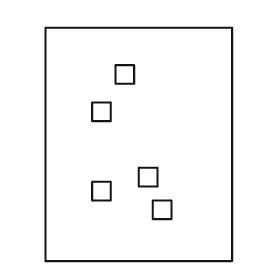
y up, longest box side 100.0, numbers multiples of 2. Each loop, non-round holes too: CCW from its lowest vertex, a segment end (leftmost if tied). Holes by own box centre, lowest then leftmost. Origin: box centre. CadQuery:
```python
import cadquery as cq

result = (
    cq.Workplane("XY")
    .moveTo(-40.0, -50.0)
    .lineTo(40.0, -50.0)
    .lineTo(40.0, 50.0)
    .lineTo(-40.0, 50.0)
    .close()
    .moveTo(6.0, -32.0)
    .lineTo(14.0, -32.0)
    .lineTo(14.0, -24.0)
    .lineTo(6.0, -24.0)
    .close()
    .moveTo(-20.0, -24.0)
    .lineTo(-12.0, -24.0)
    .lineTo(-12.0, -16.0)
    .lineTo(-20.0, -16.0)
    .close()
    .moveTo(0.0, -18.0)
    .lineTo(8.0, -18.0)
    .lineTo(8.0, -10.0)
    .lineTo(0.0, -10.0)
    .close()
    .moveTo(-20.0, 10.0)
    .lineTo(-12.0, 10.0)
    .lineTo(-12.0, 18.0)
    .lineTo(-20.0, 18.0)
    .close()
    .moveTo(-10.0, 26.0)
    .lineTo(-2.0, 26.0)
    .lineTo(-2.0, 34.0)
    .lineTo(-10.0, 34.0)
    .close()
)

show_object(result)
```